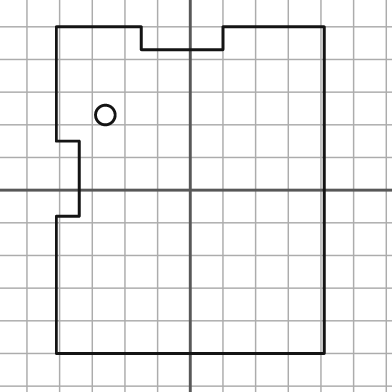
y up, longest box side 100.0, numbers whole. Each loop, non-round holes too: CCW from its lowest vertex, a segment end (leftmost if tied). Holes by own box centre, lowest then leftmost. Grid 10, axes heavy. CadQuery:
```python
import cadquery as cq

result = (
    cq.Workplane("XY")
    .moveTo(-41.0, -50.0)
    .lineTo(41.0, -50.0)
    .lineTo(41.0, 50.0)
    .lineTo(10.0, 50.0)
    .lineTo(10.0, 43.0)
    .lineTo(-15.0, 43.0)
    .lineTo(-15.0, 50.0)
    .lineTo(-41.0, 50.0)
    .lineTo(-41.0, 15.0)
    .lineTo(-34.0, 15.0)
    .lineTo(-34.0, -8.0)
    .lineTo(-41.0, -8.0)
    .close()
    .moveTo(-26.0, 23.0)
    .circle(3.0)
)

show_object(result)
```